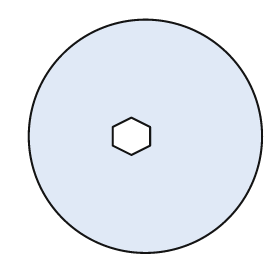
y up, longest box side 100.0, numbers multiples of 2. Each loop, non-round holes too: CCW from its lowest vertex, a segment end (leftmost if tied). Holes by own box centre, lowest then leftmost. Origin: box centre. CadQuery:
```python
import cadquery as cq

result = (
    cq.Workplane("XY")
    .moveTo(0.0, 0.0)
    .circle(50.0)
    .moveTo(-6.0, -8.0)
    .lineTo(2.0, -4.0)
    .lineTo(2.0, 4.0)
    .lineTo(-6.0, 8.0)
    .lineTo(-14.0, 4.0)
    .lineTo(-14.0, -4.0)
    .close()
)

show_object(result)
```